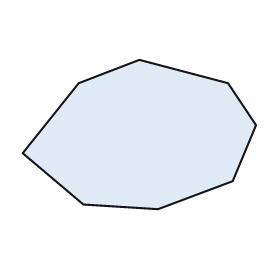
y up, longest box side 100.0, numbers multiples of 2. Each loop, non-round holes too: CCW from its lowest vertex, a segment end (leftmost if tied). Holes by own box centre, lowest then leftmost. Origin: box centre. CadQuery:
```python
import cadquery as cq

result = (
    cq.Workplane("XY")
    .moveTo(8.0, -32.0)
    .lineTo(40.0, -20.0)
    .lineTo(50.0, 4.0)
    .lineTo(38.0, 22.0)
    .lineTo(0.0, 32.0)
    .lineTo(-26.0, 22.0)
    .lineTo(-50.0, -8.0)
    .lineTo(-24.0, -30.0)
    .close()
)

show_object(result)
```